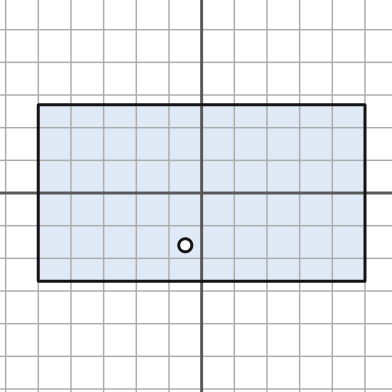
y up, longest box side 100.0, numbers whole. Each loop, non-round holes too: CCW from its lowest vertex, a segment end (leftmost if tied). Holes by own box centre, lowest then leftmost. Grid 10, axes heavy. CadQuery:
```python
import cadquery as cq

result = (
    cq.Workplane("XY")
    .moveTo(-50.0, -27.0)
    .lineTo(50.0, -27.0)
    .lineTo(50.0, 27.0)
    .lineTo(-50.0, 27.0)
    .close()
    .moveTo(-5.0, -16.0)
    .circle(2.0)
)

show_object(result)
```